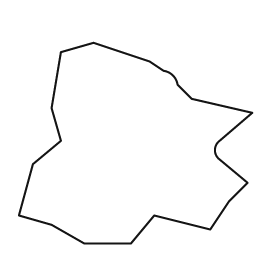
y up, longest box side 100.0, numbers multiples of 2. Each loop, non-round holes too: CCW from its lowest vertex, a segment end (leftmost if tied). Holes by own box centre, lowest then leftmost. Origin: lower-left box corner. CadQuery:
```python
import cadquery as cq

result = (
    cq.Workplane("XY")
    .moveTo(28.0, 0.0)
    .lineTo(48.0, 0.0)
    .lineTo(58.0, 12.0)
    .lineTo(82.0, 6.0)
    .lineTo(90.0, 18.0)
    .lineTo(98.0, 26.0)
    .lineTo(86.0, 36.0)
    .threePointArc((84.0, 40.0), (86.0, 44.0))
    .lineTo(100.0, 56.0)
    .lineTo(74.0, 62.0)
    .lineTo(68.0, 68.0)
    .threePointArc((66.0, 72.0), (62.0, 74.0))
    .lineTo(56.0, 78.0)
    .lineTo(32.0, 86.0)
    .lineTo(18.0, 82.0)
    .lineTo(14.0, 58.0)
    .lineTo(18.0, 44.0)
    .lineTo(6.0, 34.0)
    .lineTo(0.0, 12.0)
    .lineTo(14.0, 8.0)
    .close()
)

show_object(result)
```